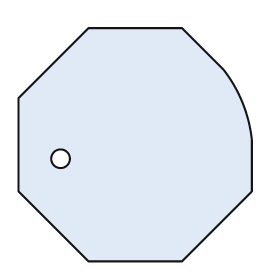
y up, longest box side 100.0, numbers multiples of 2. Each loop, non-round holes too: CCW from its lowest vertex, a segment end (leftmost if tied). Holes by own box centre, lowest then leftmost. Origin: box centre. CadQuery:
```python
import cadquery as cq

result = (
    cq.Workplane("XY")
    .moveTo(-20.0, -50.0)
    .lineTo(20.0, -50.0)
    .lineTo(50.0, -20.0)
    .lineTo(50.0, 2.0)
    .threePointArc((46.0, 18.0), (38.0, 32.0))
    .lineTo(20.0, 50.0)
    .lineTo(-20.0, 50.0)
    .lineTo(-50.0, 20.0)
    .lineTo(-50.0, -20.0)
    .close()
    .moveTo(-32.0, -6.0)
    .circle(4.0)
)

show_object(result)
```